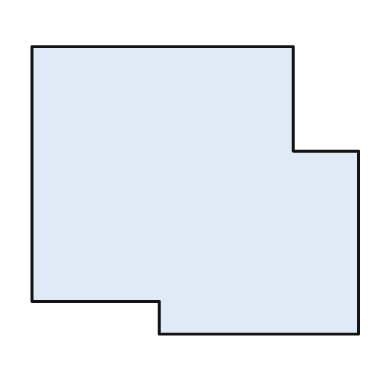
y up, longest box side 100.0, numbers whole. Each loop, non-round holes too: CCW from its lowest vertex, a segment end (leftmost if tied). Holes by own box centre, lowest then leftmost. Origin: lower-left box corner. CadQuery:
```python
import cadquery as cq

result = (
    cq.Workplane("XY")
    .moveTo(39.0, 0.0)
    .lineTo(100.0, 0.0)
    .lineTo(100.0, 56.0)
    .lineTo(80.0, 56.0)
    .lineTo(80.0, 88.0)
    .lineTo(0.0, 88.0)
    .lineTo(0.0, 10.0)
    .lineTo(39.0, 10.0)
    .close()
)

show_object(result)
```